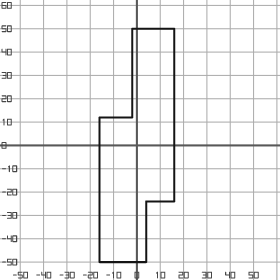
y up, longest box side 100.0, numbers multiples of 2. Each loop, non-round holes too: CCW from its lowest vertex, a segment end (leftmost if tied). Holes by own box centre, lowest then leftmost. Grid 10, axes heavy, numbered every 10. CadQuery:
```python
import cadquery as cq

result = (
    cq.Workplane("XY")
    .moveTo(-16.0, -50.0)
    .lineTo(4.0, -50.0)
    .lineTo(4.0, -24.0)
    .lineTo(16.0, -24.0)
    .lineTo(16.0, 50.0)
    .lineTo(-2.0, 50.0)
    .lineTo(-2.0, 12.0)
    .lineTo(-16.0, 12.0)
    .close()
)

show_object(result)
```